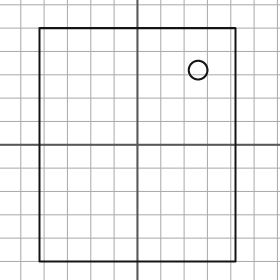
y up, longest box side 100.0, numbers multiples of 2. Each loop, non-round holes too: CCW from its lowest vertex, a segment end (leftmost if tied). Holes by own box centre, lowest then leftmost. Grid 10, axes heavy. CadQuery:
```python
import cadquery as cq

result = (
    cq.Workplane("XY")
    .moveTo(-42.0, -50.0)
    .lineTo(42.0, -50.0)
    .lineTo(42.0, 50.0)
    .lineTo(-42.0, 50.0)
    .close()
    .moveTo(26.0, 32.0)
    .circle(4.0)
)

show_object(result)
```